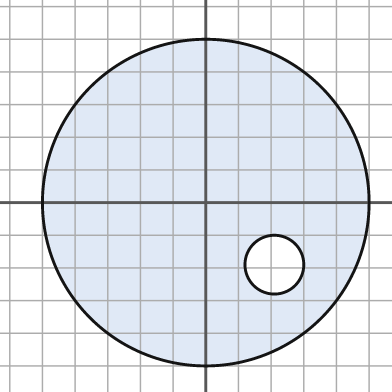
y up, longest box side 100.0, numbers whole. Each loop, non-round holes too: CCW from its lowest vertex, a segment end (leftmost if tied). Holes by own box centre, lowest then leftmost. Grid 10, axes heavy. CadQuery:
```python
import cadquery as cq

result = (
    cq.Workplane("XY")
    .moveTo(0.0, 0.0)
    .circle(50.0)
    .moveTo(21.0, -19.0)
    .circle(9.0)
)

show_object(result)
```